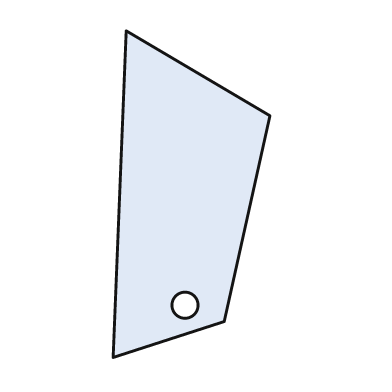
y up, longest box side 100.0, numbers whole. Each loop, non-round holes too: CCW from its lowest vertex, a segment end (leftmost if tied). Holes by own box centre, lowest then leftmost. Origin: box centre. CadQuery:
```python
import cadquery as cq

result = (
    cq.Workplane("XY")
    .moveTo(-24.0, -50.0)
    .lineTo(10.0, -39.0)
    .lineTo(24.0, 24.0)
    .lineTo(-20.0, 50.0)
    .close()
    .moveTo(-2.0, -34.0)
    .circle(4.0)
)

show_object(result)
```